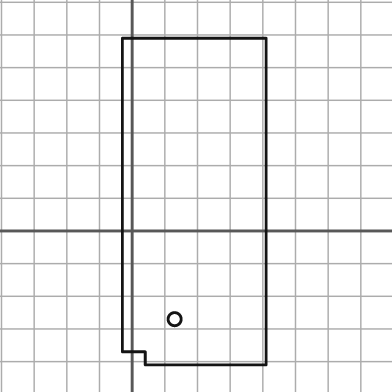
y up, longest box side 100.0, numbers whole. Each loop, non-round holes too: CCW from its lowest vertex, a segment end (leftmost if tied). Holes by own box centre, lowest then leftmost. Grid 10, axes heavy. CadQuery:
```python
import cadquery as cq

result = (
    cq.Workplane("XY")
    .moveTo(4.0, -41.0)
    .lineTo(41.0, -41.0)
    .lineTo(41.0, 59.0)
    .lineTo(-3.0, 59.0)
    .lineTo(-3.0, -37.0)
    .lineTo(4.0, -37.0)
    .close()
    .moveTo(13.0, -27.0)
    .circle(2.0)
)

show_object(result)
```